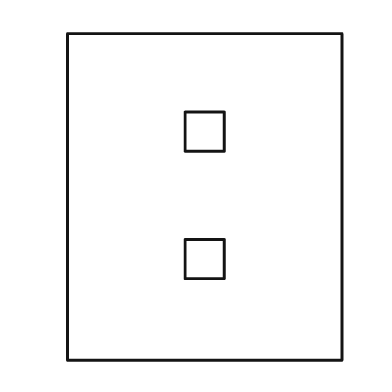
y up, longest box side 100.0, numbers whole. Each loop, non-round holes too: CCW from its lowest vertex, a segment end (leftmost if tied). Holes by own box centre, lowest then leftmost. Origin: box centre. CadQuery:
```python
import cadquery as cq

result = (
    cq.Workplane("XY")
    .moveTo(-42.0, -50.0)
    .lineTo(42.0, -50.0)
    .lineTo(42.0, 50.0)
    .lineTo(-42.0, 50.0)
    .close()
    .moveTo(-6.0, -25.0)
    .lineTo(6.0, -25.0)
    .lineTo(6.0, -13.0)
    .lineTo(-6.0, -13.0)
    .close()
    .moveTo(-6.0, 14.0)
    .lineTo(6.0, 14.0)
    .lineTo(6.0, 26.0)
    .lineTo(-6.0, 26.0)
    .close()
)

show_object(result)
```